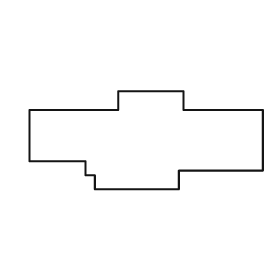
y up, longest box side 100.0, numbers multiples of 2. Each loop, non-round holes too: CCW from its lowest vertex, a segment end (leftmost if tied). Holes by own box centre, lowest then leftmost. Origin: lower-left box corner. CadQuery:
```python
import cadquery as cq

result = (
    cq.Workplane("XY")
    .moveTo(28.0, 0.0)
    .lineTo(64.0, 0.0)
    .lineTo(64.0, 8.0)
    .lineTo(100.0, 8.0)
    .lineTo(100.0, 34.0)
    .lineTo(66.0, 34.0)
    .lineTo(66.0, 42.0)
    .lineTo(38.0, 42.0)
    .lineTo(38.0, 34.0)
    .lineTo(0.0, 34.0)
    .lineTo(0.0, 12.0)
    .lineTo(24.0, 12.0)
    .lineTo(24.0, 6.0)
    .lineTo(28.0, 6.0)
    .close()
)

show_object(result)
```